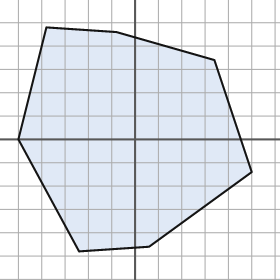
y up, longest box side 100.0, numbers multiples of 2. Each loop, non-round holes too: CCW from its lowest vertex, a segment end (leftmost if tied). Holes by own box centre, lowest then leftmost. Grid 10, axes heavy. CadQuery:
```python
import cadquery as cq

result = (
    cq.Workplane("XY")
    .moveTo(-24.0, -48.0)
    .lineTo(6.0, -46.0)
    .lineTo(50.0, -14.0)
    .lineTo(34.0, 34.0)
    .lineTo(-8.0, 46.0)
    .lineTo(-38.0, 48.0)
    .lineTo(-50.0, 0.0)
    .close()
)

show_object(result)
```